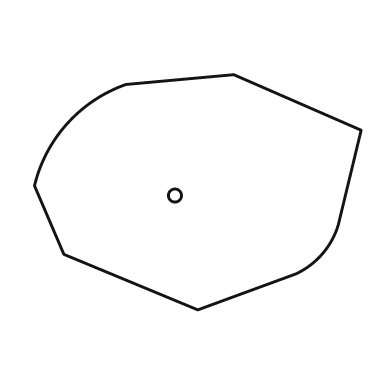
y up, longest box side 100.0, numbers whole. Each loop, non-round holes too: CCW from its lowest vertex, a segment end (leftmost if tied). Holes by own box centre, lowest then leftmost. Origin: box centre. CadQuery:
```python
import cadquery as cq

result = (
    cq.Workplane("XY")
    .moveTo(0.0, -36.0)
    .lineTo(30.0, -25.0)
    .threePointArc((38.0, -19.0), (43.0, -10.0))
    .lineTo(50.0, 19.0)
    .lineTo(11.0, 36.0)
    .lineTo(-22.0, 33.0)
    .threePointArc((-40.0, 21.0), (-50.0, 2.0))
    .lineTo(-41.0, -19.0)
    .close()
    .moveTo(-7.0, -1.0)
    .circle(2.0)
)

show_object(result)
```